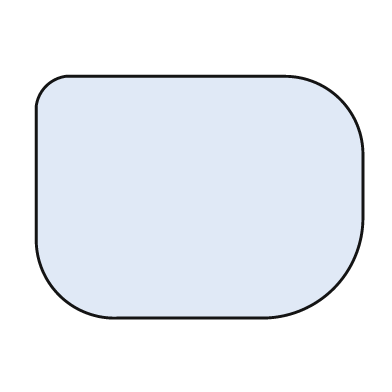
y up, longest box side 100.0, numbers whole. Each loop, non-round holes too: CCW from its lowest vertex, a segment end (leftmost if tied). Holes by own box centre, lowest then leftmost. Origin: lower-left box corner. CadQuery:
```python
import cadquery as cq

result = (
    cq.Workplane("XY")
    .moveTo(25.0, 0.0)
    .lineTo(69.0, 0.0)
    .threePointArc((91.0, 9.0), (100.0, 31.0))
    .lineTo(100.0, 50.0)
    .threePointArc((93.0, 67.0), (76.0, 74.0))
    .lineTo(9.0, 74.0)
    .threePointArc((3.0, 71.0), (0.0, 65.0))
    .lineTo(0.0, 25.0)
    .threePointArc((7.0, 7.0), (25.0, 0.0))
    .close()
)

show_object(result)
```